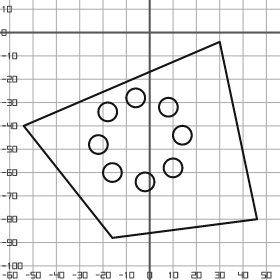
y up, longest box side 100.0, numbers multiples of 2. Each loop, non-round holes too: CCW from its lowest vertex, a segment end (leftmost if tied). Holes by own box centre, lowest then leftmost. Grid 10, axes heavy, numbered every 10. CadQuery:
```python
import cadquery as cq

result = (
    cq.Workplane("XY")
    .moveTo(-16.0, -88.0)
    .lineTo(46.0, -80.0)
    .lineTo(30.0, -4.0)
    .lineTo(-54.0, -40.0)
    .close()
    .moveTo(-2.0, -64.0)
    .circle(4.0)
    .moveTo(-16.0, -60.0)
    .circle(4.0)
    .moveTo(10.0, -58.0)
    .circle(4.0)
    .moveTo(-22.0, -48.0)
    .circle(4.0)
    .moveTo(14.0, -44.0)
    .circle(4.0)
    .moveTo(-18.0, -34.0)
    .circle(4.0)
    .moveTo(8.0, -32.0)
    .circle(4.0)
    .moveTo(-6.0, -28.0)
    .circle(4.0)
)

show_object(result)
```